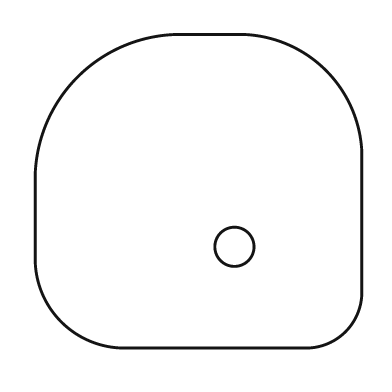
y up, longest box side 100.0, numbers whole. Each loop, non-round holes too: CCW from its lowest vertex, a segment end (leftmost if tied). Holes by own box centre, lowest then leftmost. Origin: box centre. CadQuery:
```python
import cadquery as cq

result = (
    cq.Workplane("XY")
    .moveTo(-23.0, -48.0)
    .lineTo(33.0, -48.0)
    .threePointArc((45.0, -43.0), (50.0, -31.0))
    .lineTo(50.0, 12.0)
    .threePointArc((39.0, 37.0), (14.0, 48.0))
    .lineTo(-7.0, 48.0)
    .threePointArc((-37.0, 35.0), (-50.0, 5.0))
    .lineTo(-50.0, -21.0)
    .threePointArc((-42.0, -40.0), (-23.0, -48.0))
    .close()
    .moveTo(11.0, -17.0)
    .circle(6.0)
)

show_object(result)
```